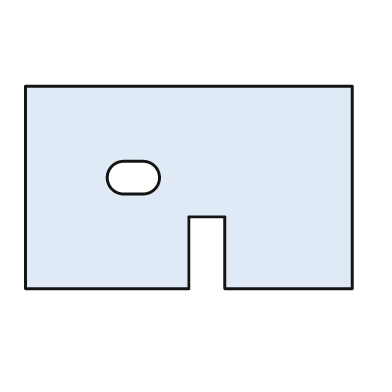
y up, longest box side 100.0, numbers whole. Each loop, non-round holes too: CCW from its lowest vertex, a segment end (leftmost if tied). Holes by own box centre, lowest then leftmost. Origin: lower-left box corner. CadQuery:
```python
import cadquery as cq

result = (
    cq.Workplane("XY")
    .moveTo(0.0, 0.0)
    .lineTo(50.0, 0.0)
    .lineTo(50.0, 22.0)
    .lineTo(61.0, 22.0)
    .lineTo(61.0, 0.0)
    .lineTo(100.0, 0.0)
    .lineTo(100.0, 62.0)
    .lineTo(0.0, 62.0)
    .close()
    .moveTo(30.0, 29.0)
    .lineTo(36.0, 29.0)
    .threePointArc((41.0, 34.0), (36.0, 39.0))
    .lineTo(30.0, 39.0)
    .threePointArc((25.0, 34.0), (30.0, 29.0))
    .close()
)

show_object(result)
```